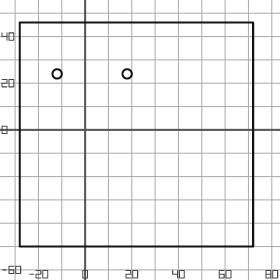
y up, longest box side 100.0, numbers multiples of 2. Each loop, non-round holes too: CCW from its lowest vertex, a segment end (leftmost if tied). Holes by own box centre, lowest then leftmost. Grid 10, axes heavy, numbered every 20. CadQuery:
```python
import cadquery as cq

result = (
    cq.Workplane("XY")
    .moveTo(-28.0, -50.0)
    .lineTo(72.0, -50.0)
    .lineTo(72.0, 46.0)
    .lineTo(-28.0, 46.0)
    .close()
    .moveTo(-12.0, 24.0)
    .circle(2.0)
    .moveTo(18.0, 24.0)
    .circle(2.0)
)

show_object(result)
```